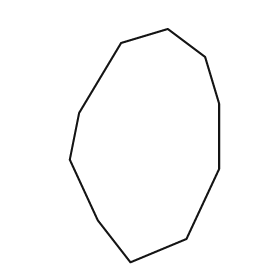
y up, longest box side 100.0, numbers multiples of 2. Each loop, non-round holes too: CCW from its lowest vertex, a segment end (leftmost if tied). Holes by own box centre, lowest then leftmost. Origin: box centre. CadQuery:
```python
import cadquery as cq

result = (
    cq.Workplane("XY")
    .moveTo(-6.0, -50.0)
    .lineTo(18.0, -40.0)
    .lineTo(32.0, -10.0)
    .lineTo(32.0, 18.0)
    .lineTo(26.0, 38.0)
    .lineTo(10.0, 50.0)
    .lineTo(-10.0, 44.0)
    .lineTo(-28.0, 14.0)
    .lineTo(-32.0, -6.0)
    .lineTo(-20.0, -32.0)
    .close()
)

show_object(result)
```